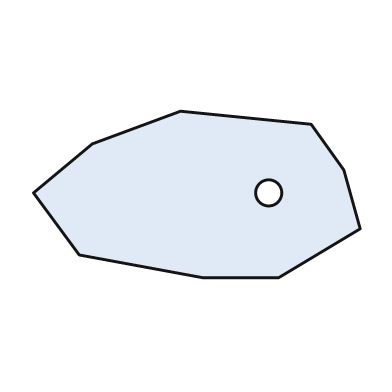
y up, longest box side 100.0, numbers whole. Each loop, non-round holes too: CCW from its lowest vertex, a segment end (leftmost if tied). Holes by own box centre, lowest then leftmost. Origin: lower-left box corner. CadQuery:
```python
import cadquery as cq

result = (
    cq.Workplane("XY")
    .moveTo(52.0, 0.0)
    .lineTo(75.0, 0.0)
    .lineTo(100.0, 15.0)
    .lineTo(95.0, 33.0)
    .lineTo(85.0, 47.0)
    .lineTo(45.0, 51.0)
    .lineTo(18.0, 41.0)
    .lineTo(0.0, 26.0)
    .lineTo(14.0, 7.0)
    .close()
    .moveTo(72.0, 26.0)
    .circle(4.0)
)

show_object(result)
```